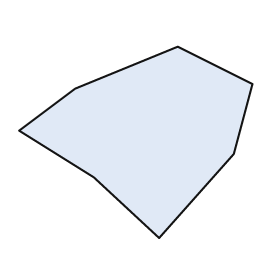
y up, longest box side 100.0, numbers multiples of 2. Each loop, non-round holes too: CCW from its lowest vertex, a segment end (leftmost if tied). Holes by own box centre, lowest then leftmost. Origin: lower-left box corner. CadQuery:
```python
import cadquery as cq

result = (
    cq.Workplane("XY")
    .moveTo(60.0, 0.0)
    .lineTo(92.0, 36.0)
    .lineTo(100.0, 66.0)
    .lineTo(68.0, 82.0)
    .lineTo(24.0, 64.0)
    .lineTo(0.0, 46.0)
    .lineTo(32.0, 26.0)
    .close()
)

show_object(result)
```